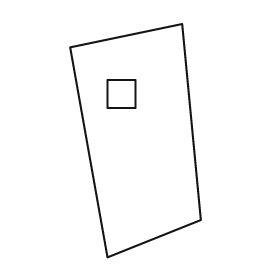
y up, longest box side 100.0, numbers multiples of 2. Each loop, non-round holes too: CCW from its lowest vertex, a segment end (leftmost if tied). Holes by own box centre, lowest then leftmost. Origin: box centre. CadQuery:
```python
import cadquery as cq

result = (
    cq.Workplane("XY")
    .moveTo(-12.0, -50.0)
    .lineTo(28.0, -34.0)
    .lineTo(20.0, 50.0)
    .lineTo(-28.0, 40.0)
    .close()
    .moveTo(-12.0, 14.0)
    .lineTo(0.0, 14.0)
    .lineTo(0.0, 26.0)
    .lineTo(-12.0, 26.0)
    .close()
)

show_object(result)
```